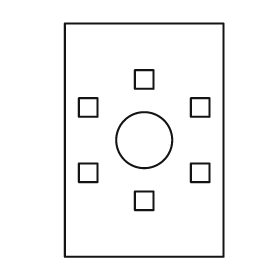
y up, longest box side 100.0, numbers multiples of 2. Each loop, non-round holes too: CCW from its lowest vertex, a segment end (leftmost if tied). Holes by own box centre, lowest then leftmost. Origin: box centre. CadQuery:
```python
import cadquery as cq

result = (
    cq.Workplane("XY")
    .moveTo(-34.0, -50.0)
    .lineTo(34.0, -50.0)
    .lineTo(34.0, 50.0)
    .lineTo(-34.0, 50.0)
    .close()
    .moveTo(-4.0, -30.0)
    .lineTo(4.0, -30.0)
    .lineTo(4.0, -22.0)
    .lineTo(-4.0, -22.0)
    .close()
    .moveTo(-28.0, -18.0)
    .lineTo(-20.0, -18.0)
    .lineTo(-20.0, -10.0)
    .lineTo(-28.0, -10.0)
    .close()
    .moveTo(20.0, -18.0)
    .lineTo(28.0, -18.0)
    .lineTo(28.0, -10.0)
    .lineTo(20.0, -10.0)
    .close()
    .moveTo(0.0, 0.0)
    .circle(12.0)
    .moveTo(-28.0, 10.0)
    .lineTo(-20.0, 10.0)
    .lineTo(-20.0, 18.0)
    .lineTo(-28.0, 18.0)
    .close()
    .moveTo(20.0, 10.0)
    .lineTo(28.0, 10.0)
    .lineTo(28.0, 18.0)
    .lineTo(20.0, 18.0)
    .close()
    .moveTo(-4.0, 22.0)
    .lineTo(4.0, 22.0)
    .lineTo(4.0, 30.0)
    .lineTo(-4.0, 30.0)
    .close()
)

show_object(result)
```